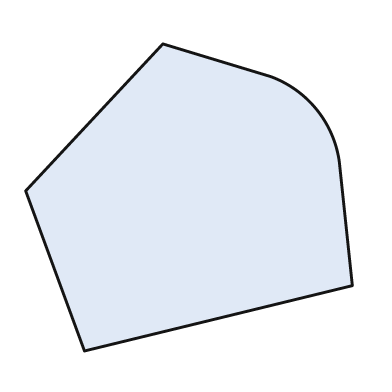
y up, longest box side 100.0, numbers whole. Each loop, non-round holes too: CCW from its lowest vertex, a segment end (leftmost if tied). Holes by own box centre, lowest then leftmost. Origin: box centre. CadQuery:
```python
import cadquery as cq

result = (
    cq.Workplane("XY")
    .moveTo(-32.0, -47.0)
    .lineTo(50.0, -27.0)
    .lineTo(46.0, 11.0)
    .threePointArc((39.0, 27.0), (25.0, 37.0))
    .lineTo(-8.0, 47.0)
    .lineTo(-50.0, 2.0)
    .close()
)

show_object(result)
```